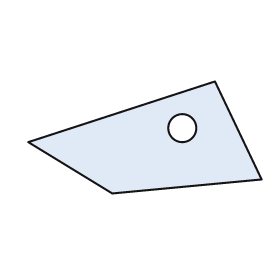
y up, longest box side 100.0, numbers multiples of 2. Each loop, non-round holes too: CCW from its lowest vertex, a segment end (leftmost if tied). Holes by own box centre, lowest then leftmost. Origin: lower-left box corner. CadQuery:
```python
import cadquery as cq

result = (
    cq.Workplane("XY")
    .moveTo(36.0, 0.0)
    .lineTo(100.0, 6.0)
    .lineTo(80.0, 48.0)
    .lineTo(0.0, 22.0)
    .close()
    .moveTo(66.0, 28.0)
    .circle(6.0)
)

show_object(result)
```